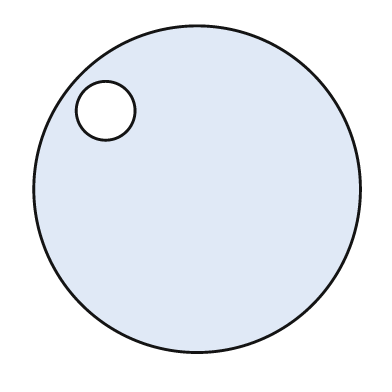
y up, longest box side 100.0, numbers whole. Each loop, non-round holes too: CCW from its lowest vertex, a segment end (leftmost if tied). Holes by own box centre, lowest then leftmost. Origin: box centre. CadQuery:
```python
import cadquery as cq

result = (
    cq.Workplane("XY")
    .moveTo(0.0, 0.0)
    .circle(50.0)
    .moveTo(-28.0, 24.0)
    .circle(9.0)
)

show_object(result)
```